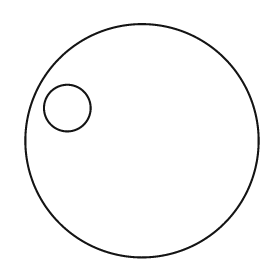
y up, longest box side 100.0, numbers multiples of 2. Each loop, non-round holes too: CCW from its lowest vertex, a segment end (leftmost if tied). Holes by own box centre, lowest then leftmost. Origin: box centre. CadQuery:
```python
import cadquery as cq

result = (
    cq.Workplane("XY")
    .moveTo(0.0, 0.0)
    .circle(50.0)
    .moveTo(-32.0, 14.0)
    .circle(10.0)
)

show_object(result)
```